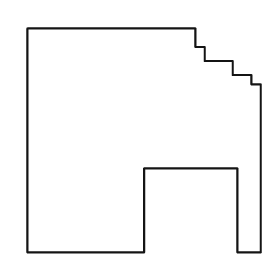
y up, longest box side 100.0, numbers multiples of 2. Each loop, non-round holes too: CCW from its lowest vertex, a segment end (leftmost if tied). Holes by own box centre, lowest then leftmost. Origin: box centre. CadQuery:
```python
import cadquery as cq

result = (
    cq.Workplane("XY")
    .moveTo(-50.0, -48.0)
    .lineTo(0.0, -48.0)
    .lineTo(0.0, -12.0)
    .lineTo(40.0, -12.0)
    .lineTo(40.0, -48.0)
    .lineTo(50.0, -48.0)
    .lineTo(50.0, 24.0)
    .lineTo(46.0, 24.0)
    .lineTo(46.0, 28.0)
    .lineTo(38.0, 28.0)
    .lineTo(38.0, 34.0)
    .lineTo(26.0, 34.0)
    .lineTo(26.0, 40.0)
    .lineTo(22.0, 40.0)
    .lineTo(22.0, 48.0)
    .lineTo(-50.0, 48.0)
    .close()
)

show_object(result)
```